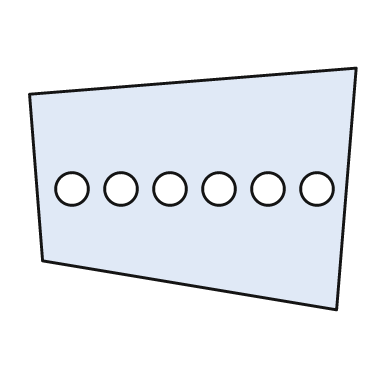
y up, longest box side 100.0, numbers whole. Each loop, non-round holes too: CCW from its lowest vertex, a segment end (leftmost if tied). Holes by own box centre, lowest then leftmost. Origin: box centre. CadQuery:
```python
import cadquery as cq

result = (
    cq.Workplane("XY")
    .moveTo(44.0, -37.0)
    .lineTo(50.0, 37.0)
    .lineTo(-50.0, 29.0)
    .lineTo(-46.0, -22.0)
    .close()
    .moveTo(-37.0, 0.0)
    .circle(5.0)
    .moveTo(-22.0, 0.0)
    .circle(5.0)
    .moveTo(-7.0, 0.0)
    .circle(5.0)
    .moveTo(8.0, 0.0)
    .circle(5.0)
    .moveTo(23.0, 0.0)
    .circle(5.0)
    .moveTo(38.0, 0.0)
    .circle(5.0)
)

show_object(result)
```